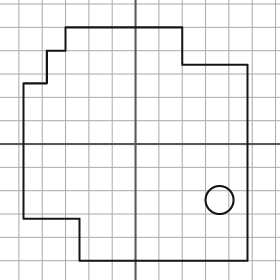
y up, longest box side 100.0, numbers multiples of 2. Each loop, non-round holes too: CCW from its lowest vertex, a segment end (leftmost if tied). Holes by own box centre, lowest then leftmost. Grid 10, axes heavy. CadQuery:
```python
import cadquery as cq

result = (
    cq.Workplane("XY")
    .moveTo(-24.0, -50.0)
    .lineTo(48.0, -50.0)
    .lineTo(48.0, 34.0)
    .lineTo(20.0, 34.0)
    .lineTo(20.0, 50.0)
    .lineTo(-30.0, 50.0)
    .lineTo(-30.0, 40.0)
    .lineTo(-38.0, 40.0)
    .lineTo(-38.0, 26.0)
    .lineTo(-48.0, 26.0)
    .lineTo(-48.0, -32.0)
    .lineTo(-24.0, -32.0)
    .close()
    .moveTo(36.0, -24.0)
    .circle(6.0)
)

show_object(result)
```